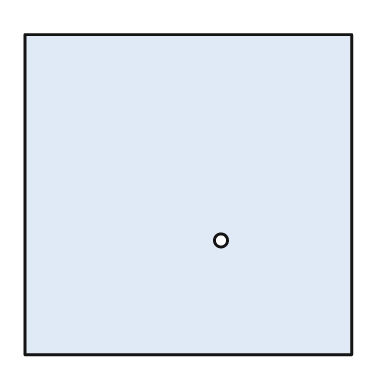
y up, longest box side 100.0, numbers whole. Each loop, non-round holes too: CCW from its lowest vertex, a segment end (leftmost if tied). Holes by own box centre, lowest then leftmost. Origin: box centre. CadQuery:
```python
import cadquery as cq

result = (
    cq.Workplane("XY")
    .moveTo(-50.0, -49.0)
    .lineTo(50.0, -49.0)
    .lineTo(50.0, 49.0)
    .lineTo(-50.0, 49.0)
    .close()
    .moveTo(10.0, -14.0)
    .circle(2.0)
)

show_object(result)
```